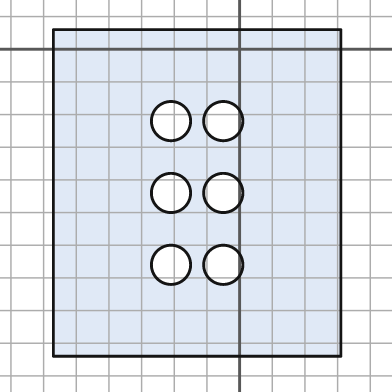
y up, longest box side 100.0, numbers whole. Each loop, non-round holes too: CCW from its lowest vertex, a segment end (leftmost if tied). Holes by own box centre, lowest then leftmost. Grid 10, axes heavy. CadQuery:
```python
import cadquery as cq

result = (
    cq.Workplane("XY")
    .moveTo(-57.0, -94.0)
    .lineTo(31.0, -94.0)
    .lineTo(31.0, 6.0)
    .lineTo(-57.0, 6.0)
    .close()
    .moveTo(-21.0, -66.0)
    .circle(6.0)
    .moveTo(-5.0, -66.0)
    .circle(6.0)
    .moveTo(-21.0, -44.0)
    .circle(6.0)
    .moveTo(-5.0, -44.0)
    .circle(6.0)
    .moveTo(-21.0, -22.0)
    .circle(6.0)
    .moveTo(-5.0, -22.0)
    .circle(6.0)
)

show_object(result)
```